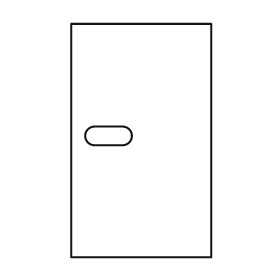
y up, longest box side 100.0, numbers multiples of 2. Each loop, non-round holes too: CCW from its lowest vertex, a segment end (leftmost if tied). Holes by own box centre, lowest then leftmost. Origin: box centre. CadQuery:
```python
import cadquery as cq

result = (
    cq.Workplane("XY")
    .moveTo(-30.0, -50.0)
    .lineTo(30.0, -50.0)
    .lineTo(30.0, 50.0)
    .lineTo(-30.0, 50.0)
    .close()
    .moveTo(-20.0, -2.0)
    .lineTo(-8.0, -2.0)
    .threePointArc((-4.0, 2.0), (-8.0, 6.0))
    .lineTo(-20.0, 6.0)
    .threePointArc((-24.0, 2.0), (-20.0, -2.0))
    .close()
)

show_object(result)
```